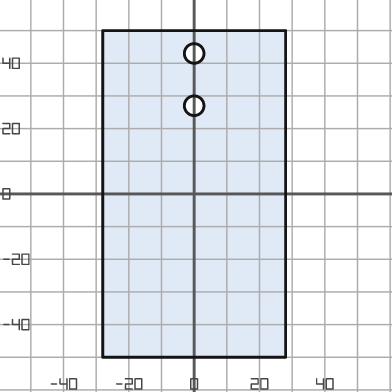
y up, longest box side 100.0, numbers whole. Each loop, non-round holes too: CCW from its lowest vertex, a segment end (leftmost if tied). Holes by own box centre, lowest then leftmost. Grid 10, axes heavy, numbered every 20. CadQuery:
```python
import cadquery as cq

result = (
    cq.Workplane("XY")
    .moveTo(-28.0, -50.0)
    .lineTo(28.0, -50.0)
    .lineTo(28.0, 50.0)
    .lineTo(-28.0, 50.0)
    .close()
    .moveTo(0.0, 27.0)
    .circle(3.0)
    .moveTo(0.0, 43.0)
    .circle(3.0)
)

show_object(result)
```